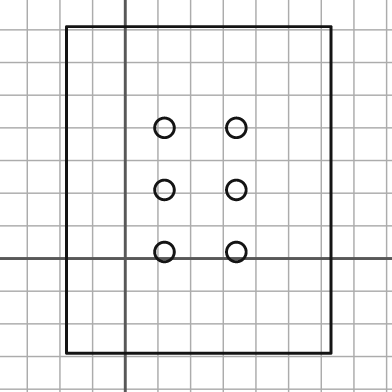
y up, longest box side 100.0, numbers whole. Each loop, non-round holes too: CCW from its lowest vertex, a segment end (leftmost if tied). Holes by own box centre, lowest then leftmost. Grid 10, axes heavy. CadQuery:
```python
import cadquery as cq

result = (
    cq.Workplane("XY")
    .moveTo(-18.0, -29.0)
    .lineTo(63.0, -29.0)
    .lineTo(63.0, 71.0)
    .lineTo(-18.0, 71.0)
    .close()
    .moveTo(12.0, 2.0)
    .circle(3.0)
    .moveTo(34.0, 2.0)
    .circle(3.0)
    .moveTo(12.0, 21.0)
    .circle(3.0)
    .moveTo(34.0, 21.0)
    .circle(3.0)
    .moveTo(12.0, 40.0)
    .circle(3.0)
    .moveTo(34.0, 40.0)
    .circle(3.0)
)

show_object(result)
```